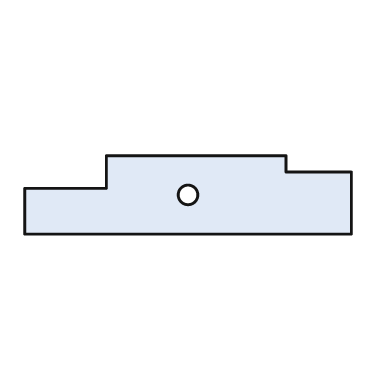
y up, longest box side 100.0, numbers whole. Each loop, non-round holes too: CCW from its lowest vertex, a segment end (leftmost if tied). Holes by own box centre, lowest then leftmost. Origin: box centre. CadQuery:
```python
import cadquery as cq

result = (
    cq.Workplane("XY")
    .moveTo(-50.0, -12.0)
    .lineTo(50.0, -12.0)
    .lineTo(50.0, 7.0)
    .lineTo(30.0, 7.0)
    .lineTo(30.0, 12.0)
    .lineTo(-25.0, 12.0)
    .lineTo(-25.0, 2.0)
    .lineTo(-50.0, 2.0)
    .close()
    .moveTo(0.0, 0.0)
    .circle(3.0)
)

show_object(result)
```